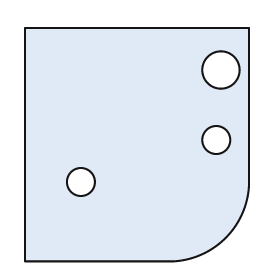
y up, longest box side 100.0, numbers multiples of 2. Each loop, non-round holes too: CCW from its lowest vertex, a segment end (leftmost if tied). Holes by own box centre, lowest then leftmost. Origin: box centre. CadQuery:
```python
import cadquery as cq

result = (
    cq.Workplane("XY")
    .moveTo(-48.0, -50.0)
    .lineTo(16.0, -50.0)
    .threePointArc((38.0, -40.0), (48.0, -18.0))
    .lineTo(48.0, 50.0)
    .lineTo(-48.0, 50.0)
    .close()
    .moveTo(-24.0, -16.0)
    .circle(6.0)
    .moveTo(34.0, 2.0)
    .circle(6.0)
    .moveTo(36.0, 32.0)
    .circle(8.0)
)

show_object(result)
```